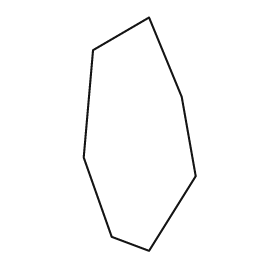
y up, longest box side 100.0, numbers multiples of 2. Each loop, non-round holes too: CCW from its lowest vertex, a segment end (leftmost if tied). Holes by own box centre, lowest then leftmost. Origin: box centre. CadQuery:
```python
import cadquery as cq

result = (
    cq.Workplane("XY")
    .moveTo(4.0, -50.0)
    .lineTo(24.0, -18.0)
    .lineTo(18.0, 16.0)
    .lineTo(4.0, 50.0)
    .lineTo(-20.0, 36.0)
    .lineTo(-24.0, -10.0)
    .lineTo(-12.0, -44.0)
    .close()
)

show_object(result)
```